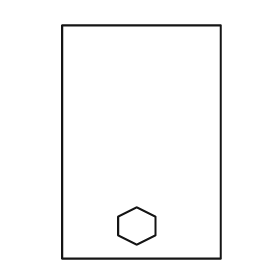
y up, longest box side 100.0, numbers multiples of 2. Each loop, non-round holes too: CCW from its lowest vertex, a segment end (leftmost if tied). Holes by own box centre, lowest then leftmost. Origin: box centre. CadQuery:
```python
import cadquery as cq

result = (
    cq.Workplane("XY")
    .moveTo(-34.0, -50.0)
    .lineTo(34.0, -50.0)
    .lineTo(34.0, 50.0)
    .lineTo(-34.0, 50.0)
    .close()
    .moveTo(-2.0, -44.0)
    .lineTo(6.0, -40.0)
    .lineTo(6.0, -32.0)
    .lineTo(-2.0, -28.0)
    .lineTo(-10.0, -32.0)
    .lineTo(-10.0, -40.0)
    .close()
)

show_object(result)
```